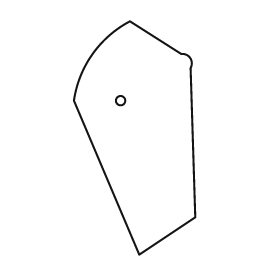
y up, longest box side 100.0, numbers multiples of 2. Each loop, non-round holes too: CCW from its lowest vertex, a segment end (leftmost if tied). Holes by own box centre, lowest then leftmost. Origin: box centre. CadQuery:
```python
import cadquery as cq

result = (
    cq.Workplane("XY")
    .moveTo(2.0, -50.0)
    .lineTo(26.0, -34.0)
    .lineTo(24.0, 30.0)
    .threePointArc((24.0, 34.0), (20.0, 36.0))
    .lineTo(-2.0, 50.0)
    .threePointArc((-18.0, 36.0), (-26.0, 16.0))
    .close()
    .moveTo(-6.0, 16.0)
    .circle(2.0)
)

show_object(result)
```